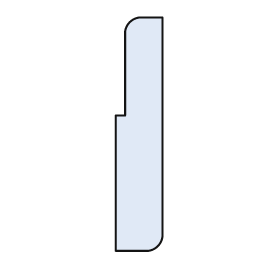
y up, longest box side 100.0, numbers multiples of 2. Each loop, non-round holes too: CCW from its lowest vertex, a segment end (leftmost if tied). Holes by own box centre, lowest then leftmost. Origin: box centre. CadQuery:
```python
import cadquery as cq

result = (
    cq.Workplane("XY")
    .moveTo(-10.0, -50.0)
    .lineTo(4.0, -50.0)
    .threePointArc((8.0, -48.0), (10.0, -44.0))
    .lineTo(10.0, 50.0)
    .lineTo(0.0, 50.0)
    .threePointArc((-4.0, 48.0), (-6.0, 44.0))
    .lineTo(-6.0, 8.0)
    .lineTo(-10.0, 8.0)
    .close()
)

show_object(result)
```